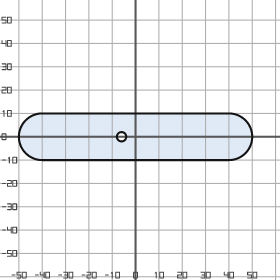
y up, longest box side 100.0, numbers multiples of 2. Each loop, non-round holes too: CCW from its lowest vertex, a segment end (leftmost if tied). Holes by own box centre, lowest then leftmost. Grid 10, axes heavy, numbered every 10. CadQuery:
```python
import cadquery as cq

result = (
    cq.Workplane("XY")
    .moveTo(-40.0, -10.0)
    .lineTo(40.0, -10.0)
    .threePointArc((50.0, 0.0), (40.0, 10.0))
    .lineTo(-40.0, 10.0)
    .threePointArc((-50.0, 0.0), (-40.0, -10.0))
    .close()
    .moveTo(-6.0, 0.0)
    .circle(2.0)
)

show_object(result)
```